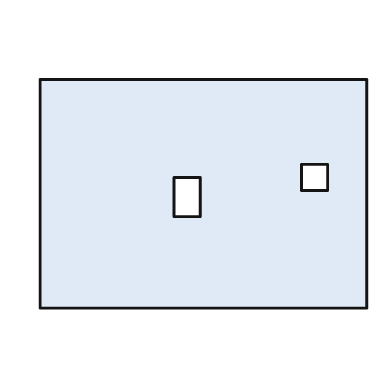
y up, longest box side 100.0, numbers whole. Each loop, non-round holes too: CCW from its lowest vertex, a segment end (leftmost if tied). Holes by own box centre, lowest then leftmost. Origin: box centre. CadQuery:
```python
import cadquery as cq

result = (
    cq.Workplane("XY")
    .moveTo(-50.0, -35.0)
    .lineTo(50.0, -35.0)
    .lineTo(50.0, 35.0)
    .lineTo(-50.0, 35.0)
    .close()
    .moveTo(-9.0, -7.0)
    .lineTo(-1.0, -7.0)
    .lineTo(-1.0, 5.0)
    .lineTo(-9.0, 5.0)
    .close()
    .moveTo(30.0, 1.0)
    .lineTo(38.0, 1.0)
    .lineTo(38.0, 9.0)
    .lineTo(30.0, 9.0)
    .close()
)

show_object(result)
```